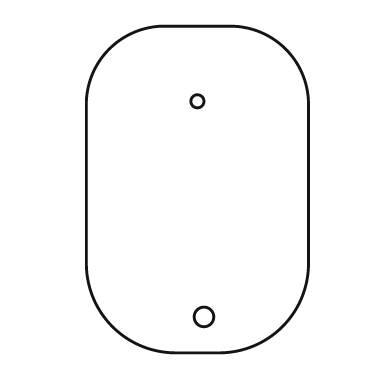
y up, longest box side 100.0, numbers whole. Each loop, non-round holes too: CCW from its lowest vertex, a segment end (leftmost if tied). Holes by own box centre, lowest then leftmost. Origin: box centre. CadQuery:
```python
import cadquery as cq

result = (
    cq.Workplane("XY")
    .moveTo(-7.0, -50.0)
    .lineTo(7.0, -50.0)
    .threePointArc((26.0, -42.0), (34.0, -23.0))
    .lineTo(34.0, 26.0)
    .threePointArc((27.0, 43.0), (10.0, 50.0))
    .lineTo(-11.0, 50.0)
    .threePointArc((-27.0, 43.0), (-34.0, 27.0))
    .lineTo(-34.0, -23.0)
    .threePointArc((-26.0, -42.0), (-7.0, -50.0))
    .close()
    .moveTo(2.0, -39.0)
    .circle(3.0)
    .moveTo(0.0, 27.0)
    .circle(2.0)
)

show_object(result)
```